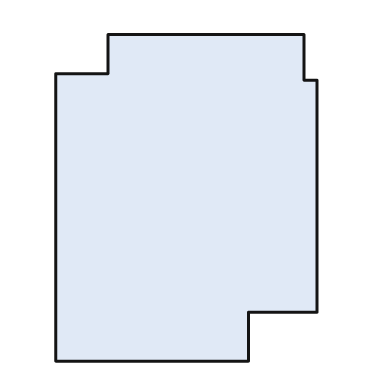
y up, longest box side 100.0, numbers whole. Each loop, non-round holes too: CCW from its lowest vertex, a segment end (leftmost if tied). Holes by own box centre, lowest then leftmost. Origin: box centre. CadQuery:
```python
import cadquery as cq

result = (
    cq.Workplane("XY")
    .moveTo(-40.0, -50.0)
    .lineTo(19.0, -50.0)
    .lineTo(19.0, -35.0)
    .lineTo(40.0, -35.0)
    .lineTo(40.0, 36.0)
    .lineTo(36.0, 36.0)
    .lineTo(36.0, 50.0)
    .lineTo(-24.0, 50.0)
    .lineTo(-24.0, 38.0)
    .lineTo(-40.0, 38.0)
    .close()
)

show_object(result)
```